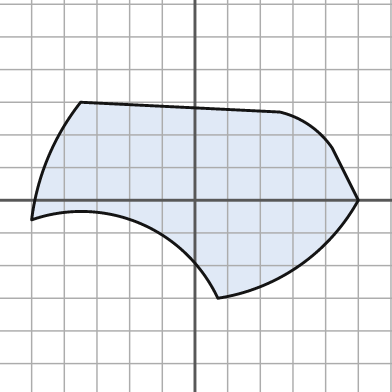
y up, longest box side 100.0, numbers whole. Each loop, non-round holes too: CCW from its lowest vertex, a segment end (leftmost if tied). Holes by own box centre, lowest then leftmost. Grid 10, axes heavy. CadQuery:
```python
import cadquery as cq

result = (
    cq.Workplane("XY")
    .moveTo(7.0, -30.0)
    .threePointArc((32.0, -20.0), (50.0, 0.0))
    .lineTo(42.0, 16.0)
    .threePointArc((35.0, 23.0), (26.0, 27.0))
    .lineTo(-35.0, 30.0)
    .threePointArc((-45.0, 13.0), (-50.0, -6.0))
    .threePointArc((-17.0, -7.0), (7.0, -30.0))
    .close()
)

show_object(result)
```